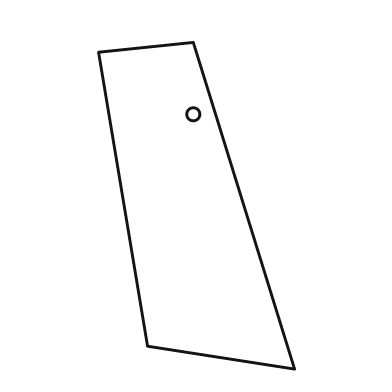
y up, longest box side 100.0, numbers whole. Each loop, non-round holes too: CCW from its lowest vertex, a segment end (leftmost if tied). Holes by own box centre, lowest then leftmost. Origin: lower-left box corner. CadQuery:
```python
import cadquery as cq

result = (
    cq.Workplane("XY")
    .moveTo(60.0, 0.0)
    .lineTo(29.0, 100.0)
    .lineTo(0.0, 97.0)
    .lineTo(15.0, 7.0)
    .close()
    .moveTo(29.0, 78.0)
    .circle(2.0)
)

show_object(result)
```